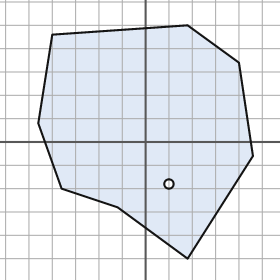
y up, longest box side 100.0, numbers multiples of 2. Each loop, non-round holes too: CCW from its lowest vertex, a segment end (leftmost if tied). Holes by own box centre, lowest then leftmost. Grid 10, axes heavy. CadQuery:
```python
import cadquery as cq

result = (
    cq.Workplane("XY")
    .moveTo(18.0, -50.0)
    .lineTo(46.0, -6.0)
    .lineTo(40.0, 34.0)
    .lineTo(18.0, 50.0)
    .lineTo(-40.0, 46.0)
    .lineTo(-46.0, 8.0)
    .lineTo(-36.0, -20.0)
    .lineTo(-12.0, -28.0)
    .close()
    .moveTo(10.0, -18.0)
    .circle(2.0)
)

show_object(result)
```